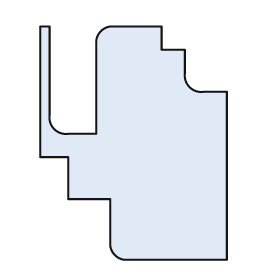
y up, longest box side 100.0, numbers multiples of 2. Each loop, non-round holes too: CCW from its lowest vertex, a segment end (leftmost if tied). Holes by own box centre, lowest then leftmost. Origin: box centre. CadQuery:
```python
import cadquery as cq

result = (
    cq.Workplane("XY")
    .moveTo(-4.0, -50.0)
    .lineTo(40.0, -50.0)
    .lineTo(40.0, 22.0)
    .lineTo(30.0, 22.0)
    .threePointArc((24.0, 24.0), (22.0, 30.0))
    .lineTo(22.0, 40.0)
    .lineTo(12.0, 40.0)
    .lineTo(12.0, 50.0)
    .lineTo(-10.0, 50.0)
    .threePointArc((-14.0, 48.0), (-16.0, 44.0))
    .lineTo(-16.0, 4.0)
    .lineTo(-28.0, 4.0)
    .threePointArc((-34.0, 6.0), (-36.0, 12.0))
    .lineTo(-36.0, 50.0)
    .lineTo(-40.0, 50.0)
    .lineTo(-40.0, -6.0)
    .lineTo(-28.0, -6.0)
    .lineTo(-28.0, -24.0)
    .lineTo(-10.0, -24.0)
    .lineTo(-10.0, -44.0)
    .threePointArc((-8.0, -48.0), (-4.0, -50.0))
    .close()
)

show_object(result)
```